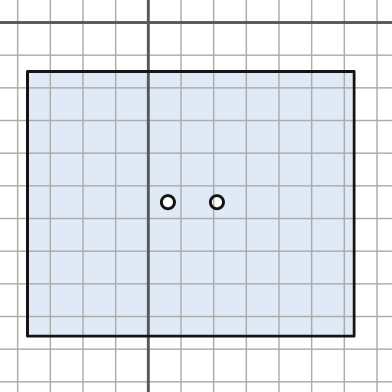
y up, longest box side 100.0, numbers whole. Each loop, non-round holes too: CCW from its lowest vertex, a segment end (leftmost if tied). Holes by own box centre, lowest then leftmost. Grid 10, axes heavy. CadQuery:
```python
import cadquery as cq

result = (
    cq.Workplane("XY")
    .moveTo(-37.0, -96.0)
    .lineTo(63.0, -96.0)
    .lineTo(63.0, -15.0)
    .lineTo(-37.0, -15.0)
    .close()
    .moveTo(6.0, -55.0)
    .circle(2.0)
    .moveTo(21.0, -55.0)
    .circle(2.0)
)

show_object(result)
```